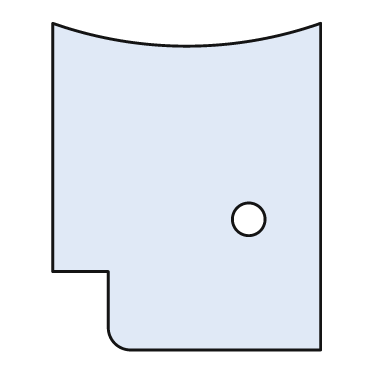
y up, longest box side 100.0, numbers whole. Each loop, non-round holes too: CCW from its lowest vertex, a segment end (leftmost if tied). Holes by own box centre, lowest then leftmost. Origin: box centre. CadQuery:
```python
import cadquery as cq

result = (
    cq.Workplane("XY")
    .moveTo(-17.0, -50.0)
    .lineTo(41.0, -50.0)
    .lineTo(41.0, 50.0)
    .threePointArc((0.0, 43.0), (-41.0, 50.0))
    .lineTo(-41.0, -26.0)
    .lineTo(-24.0, -26.0)
    .lineTo(-24.0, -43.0)
    .threePointArc((-22.0, -48.0), (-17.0, -50.0))
    .close()
    .moveTo(19.0, -10.0)
    .circle(5.0)
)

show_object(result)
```